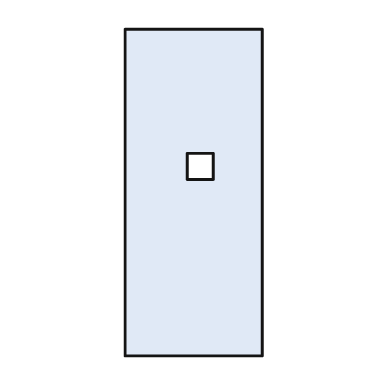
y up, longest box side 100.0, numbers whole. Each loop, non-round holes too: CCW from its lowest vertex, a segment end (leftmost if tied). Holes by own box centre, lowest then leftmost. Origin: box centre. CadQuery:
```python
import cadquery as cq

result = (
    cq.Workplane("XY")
    .moveTo(-21.0, -50.0)
    .lineTo(21.0, -50.0)
    .lineTo(21.0, 50.0)
    .lineTo(-21.0, 50.0)
    .close()
    .moveTo(-2.0, 4.0)
    .lineTo(6.0, 4.0)
    .lineTo(6.0, 12.0)
    .lineTo(-2.0, 12.0)
    .close()
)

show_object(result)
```